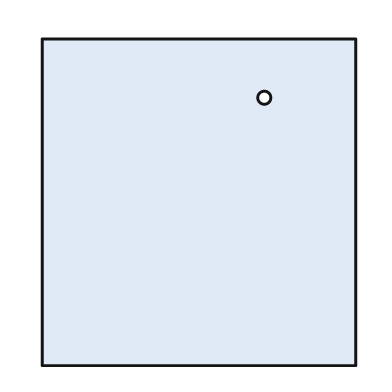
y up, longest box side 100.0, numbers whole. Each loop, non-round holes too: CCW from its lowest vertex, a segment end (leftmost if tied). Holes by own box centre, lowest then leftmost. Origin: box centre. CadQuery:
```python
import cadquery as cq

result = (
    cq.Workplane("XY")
    .moveTo(-48.0, -50.0)
    .lineTo(48.0, -50.0)
    .lineTo(48.0, 50.0)
    .lineTo(-48.0, 50.0)
    .close()
    .moveTo(20.0, 32.0)
    .circle(2.0)
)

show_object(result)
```